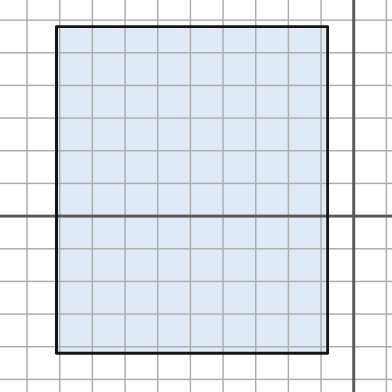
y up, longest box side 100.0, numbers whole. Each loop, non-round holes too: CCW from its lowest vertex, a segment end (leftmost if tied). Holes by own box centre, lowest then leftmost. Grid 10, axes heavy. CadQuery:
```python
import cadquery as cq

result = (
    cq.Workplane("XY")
    .moveTo(-91.0, -42.0)
    .lineTo(-8.0, -42.0)
    .lineTo(-8.0, 58.0)
    .lineTo(-91.0, 58.0)
    .close()
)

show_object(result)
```